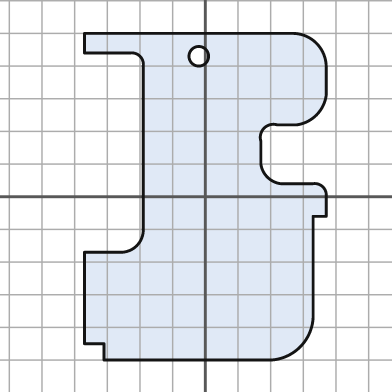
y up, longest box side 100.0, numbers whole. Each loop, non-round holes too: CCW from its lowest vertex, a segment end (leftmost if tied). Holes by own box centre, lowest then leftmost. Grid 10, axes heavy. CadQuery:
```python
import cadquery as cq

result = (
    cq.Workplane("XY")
    .moveTo(-31.0, -50.0)
    .lineTo(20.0, -50.0)
    .threePointArc((29.0, -46.0), (33.0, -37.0))
    .lineTo(33.0, -6.0)
    .lineTo(37.0, -6.0)
    .lineTo(37.0, 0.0)
    .threePointArc((36.0, 3.0), (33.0, 4.0))
    .lineTo(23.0, 4.0)
    .threePointArc((19.0, 6.0), (17.0, 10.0))
    .lineTo(17.0, 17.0)
    .threePointArc((18.0, 21.0), (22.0, 22.0))
    .lineTo(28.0, 22.0)
    .threePointArc((34.0, 25.0), (37.0, 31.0))
    .lineTo(37.0, 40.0)
    .threePointArc((34.0, 47.0), (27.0, 50.0))
    .lineTo(-37.0, 50.0)
    .lineTo(-37.0, 44.0)
    .lineTo(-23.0, 44.0)
    .threePointArc((-20.0, 43.0), (-19.0, 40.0))
    .lineTo(-19.0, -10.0)
    .threePointArc((-21.0, -15.0), (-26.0, -17.0))
    .lineTo(-37.0, -17.0)
    .lineTo(-37.0, -45.0)
    .lineTo(-31.0, -45.0)
    .close()
    .moveTo(-2.0, 43.0)
    .circle(3.0)
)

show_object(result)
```